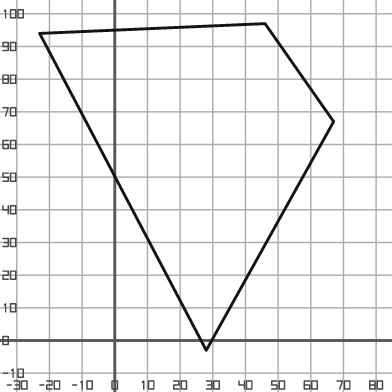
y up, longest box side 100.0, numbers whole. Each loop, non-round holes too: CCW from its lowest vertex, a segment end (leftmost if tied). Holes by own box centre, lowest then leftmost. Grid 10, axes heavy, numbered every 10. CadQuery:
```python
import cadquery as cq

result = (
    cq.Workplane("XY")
    .moveTo(28.0, -3.0)
    .lineTo(67.0, 67.0)
    .lineTo(46.0, 97.0)
    .lineTo(-23.0, 94.0)
    .close()
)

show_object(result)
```